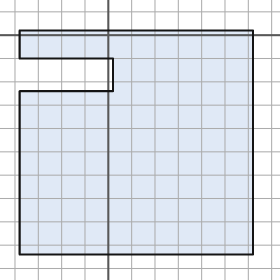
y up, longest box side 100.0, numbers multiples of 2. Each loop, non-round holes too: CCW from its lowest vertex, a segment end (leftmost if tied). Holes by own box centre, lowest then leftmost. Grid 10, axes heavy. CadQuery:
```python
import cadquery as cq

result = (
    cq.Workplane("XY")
    .moveTo(-38.0, -94.0)
    .lineTo(62.0, -94.0)
    .lineTo(62.0, 2.0)
    .lineTo(-38.0, 2.0)
    .lineTo(-38.0, -10.0)
    .lineTo(2.0, -10.0)
    .lineTo(2.0, -24.0)
    .lineTo(-38.0, -24.0)
    .close()
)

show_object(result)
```